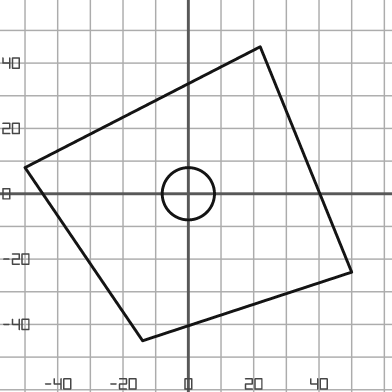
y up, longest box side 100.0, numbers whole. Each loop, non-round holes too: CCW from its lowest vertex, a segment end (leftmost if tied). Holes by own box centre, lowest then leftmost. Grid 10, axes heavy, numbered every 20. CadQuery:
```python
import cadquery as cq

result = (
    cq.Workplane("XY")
    .moveTo(-14.0, -45.0)
    .lineTo(50.0, -24.0)
    .lineTo(22.0, 45.0)
    .lineTo(-50.0, 8.0)
    .close()
    .moveTo(0.0, 0.0)
    .circle(8.0)
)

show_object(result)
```